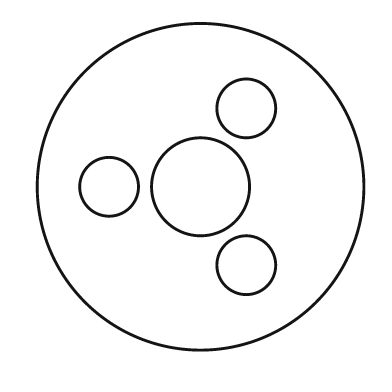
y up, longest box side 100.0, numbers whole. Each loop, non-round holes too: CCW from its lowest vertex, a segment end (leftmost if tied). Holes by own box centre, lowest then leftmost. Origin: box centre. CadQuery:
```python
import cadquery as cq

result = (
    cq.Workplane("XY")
    .moveTo(0.0, 0.0)
    .circle(50.0)
    .moveTo(14.0, -24.0)
    .circle(9.0)
    .moveTo(-28.0, 0.0)
    .circle(9.0)
    .moveTo(0.0, 0.0)
    .circle(15.0)
    .moveTo(14.0, 24.0)
    .circle(9.0)
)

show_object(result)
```